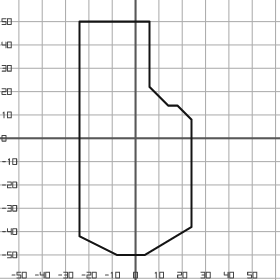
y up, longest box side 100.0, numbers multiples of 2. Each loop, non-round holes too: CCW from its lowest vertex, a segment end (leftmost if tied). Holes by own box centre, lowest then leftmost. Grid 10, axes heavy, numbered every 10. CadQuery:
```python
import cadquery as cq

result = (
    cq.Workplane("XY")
    .moveTo(-8.0, -50.0)
    .lineTo(4.0, -50.0)
    .lineTo(24.0, -38.0)
    .lineTo(24.0, 8.0)
    .lineTo(18.0, 14.0)
    .lineTo(14.0, 14.0)
    .lineTo(6.0, 22.0)
    .lineTo(6.0, 50.0)
    .lineTo(-24.0, 50.0)
    .lineTo(-24.0, -42.0)
    .close()
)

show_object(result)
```